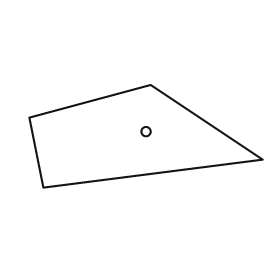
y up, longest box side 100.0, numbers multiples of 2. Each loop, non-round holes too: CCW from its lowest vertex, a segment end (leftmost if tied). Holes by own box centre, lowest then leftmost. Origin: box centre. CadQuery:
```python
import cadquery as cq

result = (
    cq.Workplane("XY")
    .moveTo(-44.0, -22.0)
    .lineTo(50.0, -10.0)
    .lineTo(2.0, 22.0)
    .lineTo(-50.0, 8.0)
    .close()
    .moveTo(0.0, 2.0)
    .circle(2.0)
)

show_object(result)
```